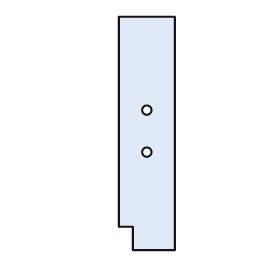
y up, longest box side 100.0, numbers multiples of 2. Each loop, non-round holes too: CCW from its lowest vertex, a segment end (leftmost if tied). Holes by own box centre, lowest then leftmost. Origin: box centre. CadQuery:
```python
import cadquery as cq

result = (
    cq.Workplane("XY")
    .moveTo(-6.0, -50.0)
    .lineTo(12.0, -50.0)
    .lineTo(12.0, 50.0)
    .lineTo(-12.0, 50.0)
    .lineTo(-12.0, -40.0)
    .lineTo(-6.0, -40.0)
    .close()
    .moveTo(0.0, -8.0)
    .circle(2.0)
    .moveTo(0.0, 10.0)
    .circle(2.0)
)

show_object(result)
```